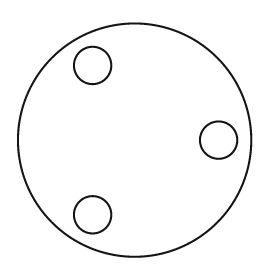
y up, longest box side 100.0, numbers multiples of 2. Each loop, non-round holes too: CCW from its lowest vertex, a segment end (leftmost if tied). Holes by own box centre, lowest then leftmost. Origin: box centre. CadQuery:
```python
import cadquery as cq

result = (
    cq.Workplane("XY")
    .moveTo(0.0, 0.0)
    .circle(50.0)
    .moveTo(-18.0, -32.0)
    .circle(8.0)
    .moveTo(36.0, 0.0)
    .circle(8.0)
    .moveTo(-18.0, 32.0)
    .circle(8.0)
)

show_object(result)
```